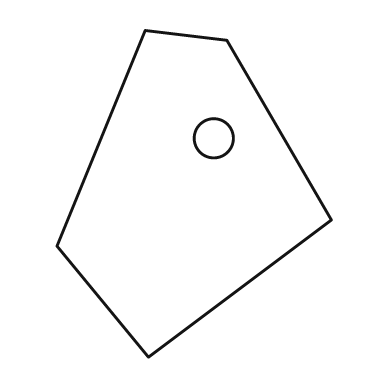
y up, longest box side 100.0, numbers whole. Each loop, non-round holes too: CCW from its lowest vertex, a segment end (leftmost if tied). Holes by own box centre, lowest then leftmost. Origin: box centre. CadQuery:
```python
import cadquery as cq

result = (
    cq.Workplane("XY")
    .moveTo(-14.0, -50.0)
    .lineTo(42.0, -8.0)
    .lineTo(10.0, 47.0)
    .lineTo(-15.0, 50.0)
    .lineTo(-42.0, -16.0)
    .close()
    .moveTo(6.0, 17.0)
    .circle(6.0)
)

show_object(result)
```